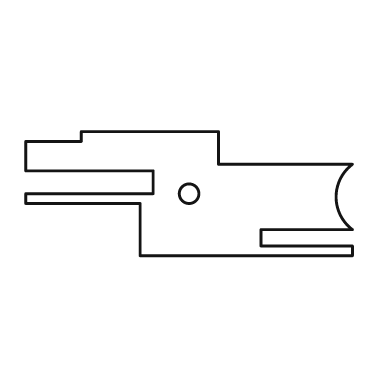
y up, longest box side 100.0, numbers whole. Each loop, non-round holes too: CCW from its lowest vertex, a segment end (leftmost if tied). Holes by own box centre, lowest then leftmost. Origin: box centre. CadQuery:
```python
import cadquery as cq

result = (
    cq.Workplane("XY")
    .moveTo(-15.0, -19.0)
    .lineTo(50.0, -19.0)
    .lineTo(50.0, -16.0)
    .lineTo(22.0, -16.0)
    .lineTo(22.0, -11.0)
    .lineTo(50.0, -11.0)
    .threePointArc((45.0, -1.0), (50.0, 9.0))
    .lineTo(9.0, 9.0)
    .lineTo(9.0, 19.0)
    .lineTo(-33.0, 19.0)
    .lineTo(-33.0, 16.0)
    .lineTo(-50.0, 16.0)
    .lineTo(-50.0, 7.0)
    .lineTo(-11.0, 7.0)
    .lineTo(-11.0, 0.0)
    .lineTo(-50.0, 0.0)
    .lineTo(-50.0, -3.0)
    .lineTo(-15.0, -3.0)
    .close()
    .moveTo(0.0, 0.0)
    .circle(3.0)
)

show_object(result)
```